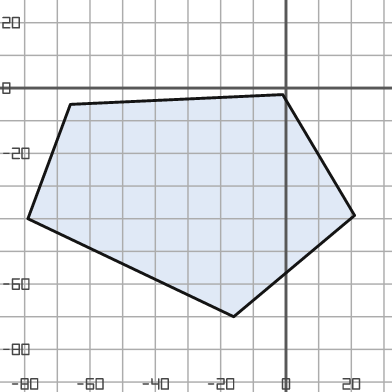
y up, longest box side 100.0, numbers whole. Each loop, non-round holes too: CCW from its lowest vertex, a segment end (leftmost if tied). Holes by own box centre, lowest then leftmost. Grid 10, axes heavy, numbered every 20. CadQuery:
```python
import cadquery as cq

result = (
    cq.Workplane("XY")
    .moveTo(-16.0, -70.0)
    .lineTo(21.0, -39.0)
    .lineTo(-1.0, -2.0)
    .lineTo(-66.0, -5.0)
    .lineTo(-79.0, -40.0)
    .close()
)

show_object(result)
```